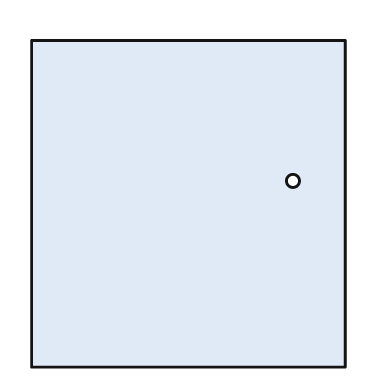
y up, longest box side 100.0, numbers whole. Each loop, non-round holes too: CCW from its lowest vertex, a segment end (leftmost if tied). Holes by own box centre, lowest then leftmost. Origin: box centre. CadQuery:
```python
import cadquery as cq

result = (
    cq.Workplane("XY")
    .moveTo(-48.0, -50.0)
    .lineTo(48.0, -50.0)
    .lineTo(48.0, 50.0)
    .lineTo(-48.0, 50.0)
    .close()
    .moveTo(32.0, 7.0)
    .circle(2.0)
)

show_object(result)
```